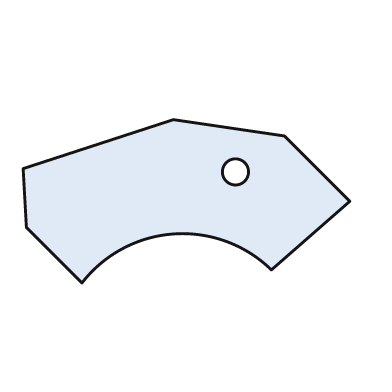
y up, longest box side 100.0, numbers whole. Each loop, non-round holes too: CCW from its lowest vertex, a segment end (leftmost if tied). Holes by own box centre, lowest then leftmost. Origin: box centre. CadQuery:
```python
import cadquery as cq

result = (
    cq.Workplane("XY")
    .moveTo(-32.0, -25.0)
    .threePointArc((-4.0, -10.0), (26.0, -21.0))
    .lineTo(50.0, 0.0)
    .lineTo(30.0, 20.0)
    .lineTo(-4.0, 25.0)
    .lineTo(-50.0, 10.0)
    .lineTo(-49.0, -8.0)
    .close()
    .moveTo(15.0, 9.0)
    .circle(4.0)
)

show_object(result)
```